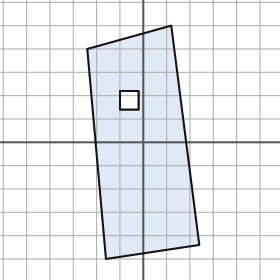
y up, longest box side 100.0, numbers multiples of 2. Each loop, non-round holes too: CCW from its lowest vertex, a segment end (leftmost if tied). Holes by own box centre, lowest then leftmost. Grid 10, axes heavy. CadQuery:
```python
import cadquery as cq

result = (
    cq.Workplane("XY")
    .moveTo(-16.0, -50.0)
    .lineTo(24.0, -44.0)
    .lineTo(12.0, 50.0)
    .lineTo(-24.0, 40.0)
    .close()
    .moveTo(-10.0, 14.0)
    .lineTo(-2.0, 14.0)
    .lineTo(-2.0, 22.0)
    .lineTo(-10.0, 22.0)
    .close()
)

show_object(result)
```